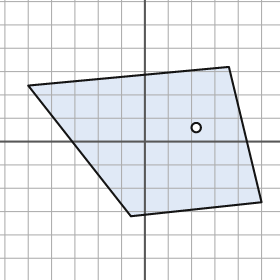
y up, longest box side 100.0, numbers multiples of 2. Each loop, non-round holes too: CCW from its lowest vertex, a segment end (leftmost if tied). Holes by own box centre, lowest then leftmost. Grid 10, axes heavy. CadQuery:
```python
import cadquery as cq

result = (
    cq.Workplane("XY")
    .moveTo(-6.0, -32.0)
    .lineTo(50.0, -26.0)
    .lineTo(36.0, 32.0)
    .lineTo(-50.0, 24.0)
    .close()
    .moveTo(22.0, 6.0)
    .circle(2.0)
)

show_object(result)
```